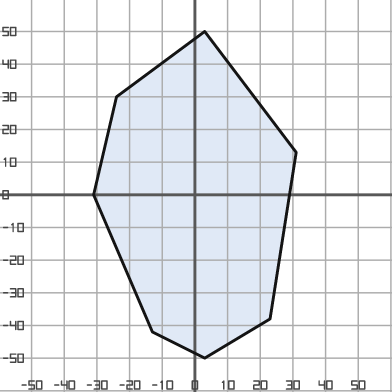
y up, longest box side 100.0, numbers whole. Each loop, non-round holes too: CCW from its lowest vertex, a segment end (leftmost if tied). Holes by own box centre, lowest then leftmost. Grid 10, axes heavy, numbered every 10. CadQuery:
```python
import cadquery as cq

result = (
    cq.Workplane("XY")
    .moveTo(3.0, -50.0)
    .lineTo(23.0, -38.0)
    .lineTo(31.0, 13.0)
    .lineTo(3.0, 50.0)
    .lineTo(-24.0, 30.0)
    .lineTo(-31.0, 0.0)
    .lineTo(-13.0, -42.0)
    .close()
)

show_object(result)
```